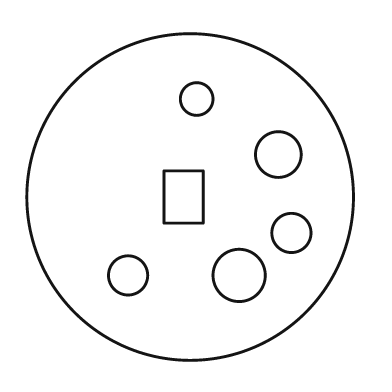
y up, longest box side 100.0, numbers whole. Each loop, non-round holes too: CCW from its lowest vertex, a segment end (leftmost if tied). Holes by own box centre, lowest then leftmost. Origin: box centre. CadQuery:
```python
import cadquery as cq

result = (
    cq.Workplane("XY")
    .moveTo(0.0, 0.0)
    .circle(50.0)
    .moveTo(-19.0, -24.0)
    .circle(6.0)
    .moveTo(15.0, -24.0)
    .circle(8.0)
    .moveTo(31.0, -11.0)
    .circle(6.0)
    .moveTo(-8.0, -8.0)
    .lineTo(4.0, -8.0)
    .lineTo(4.0, 8.0)
    .lineTo(-8.0, 8.0)
    .close()
    .moveTo(27.0, 13.0)
    .circle(7.0)
    .moveTo(2.0, 30.0)
    .circle(5.0)
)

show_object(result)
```